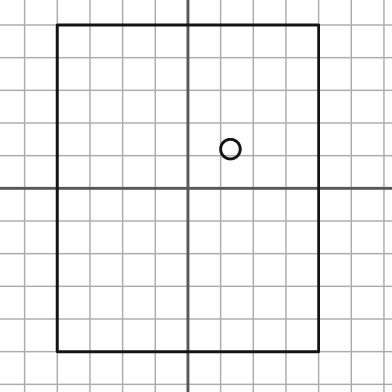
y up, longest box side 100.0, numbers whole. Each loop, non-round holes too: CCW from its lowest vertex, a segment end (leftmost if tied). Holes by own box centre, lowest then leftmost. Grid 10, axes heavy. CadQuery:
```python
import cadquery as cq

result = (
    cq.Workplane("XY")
    .moveTo(-40.0, -50.0)
    .lineTo(40.0, -50.0)
    .lineTo(40.0, 50.0)
    .lineTo(-40.0, 50.0)
    .close()
    .moveTo(13.0, 12.0)
    .circle(3.0)
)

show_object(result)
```